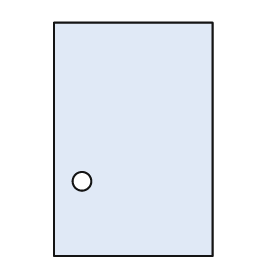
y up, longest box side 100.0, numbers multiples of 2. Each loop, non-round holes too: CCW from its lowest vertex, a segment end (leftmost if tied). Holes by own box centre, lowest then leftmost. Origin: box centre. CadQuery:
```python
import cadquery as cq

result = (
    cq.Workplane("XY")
    .moveTo(-34.0, -50.0)
    .lineTo(34.0, -50.0)
    .lineTo(34.0, 50.0)
    .lineTo(-34.0, 50.0)
    .close()
    .moveTo(-22.0, -18.0)
    .circle(4.0)
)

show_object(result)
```